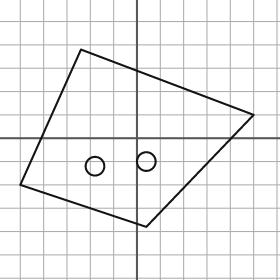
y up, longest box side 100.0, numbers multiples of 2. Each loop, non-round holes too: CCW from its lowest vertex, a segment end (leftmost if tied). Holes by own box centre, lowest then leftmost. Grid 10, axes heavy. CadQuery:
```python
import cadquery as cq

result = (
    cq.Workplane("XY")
    .moveTo(4.0, -38.0)
    .lineTo(50.0, 10.0)
    .lineTo(-24.0, 38.0)
    .lineTo(-50.0, -20.0)
    .close()
    .moveTo(-18.0, -12.0)
    .circle(4.0)
    .moveTo(4.0, -10.0)
    .circle(4.0)
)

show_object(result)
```